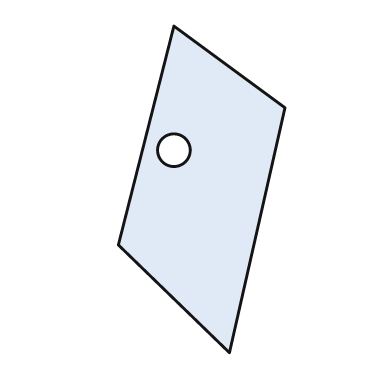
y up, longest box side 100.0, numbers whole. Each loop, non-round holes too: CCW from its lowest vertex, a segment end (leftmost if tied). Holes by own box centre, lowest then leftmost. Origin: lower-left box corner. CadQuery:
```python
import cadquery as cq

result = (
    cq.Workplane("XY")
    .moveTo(34.0, 0.0)
    .lineTo(51.0, 75.0)
    .lineTo(17.0, 100.0)
    .lineTo(0.0, 33.0)
    .close()
    .moveTo(17.0, 62.0)
    .circle(5.0)
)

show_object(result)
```